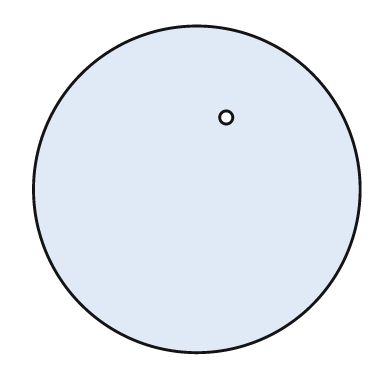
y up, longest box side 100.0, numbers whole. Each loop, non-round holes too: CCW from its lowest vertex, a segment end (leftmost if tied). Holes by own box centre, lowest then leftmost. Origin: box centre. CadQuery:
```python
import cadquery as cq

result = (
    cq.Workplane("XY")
    .moveTo(0.0, 0.0)
    .circle(50.0)
    .moveTo(9.0, 22.0)
    .circle(2.0)
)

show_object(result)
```